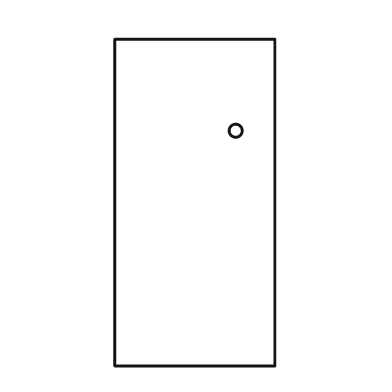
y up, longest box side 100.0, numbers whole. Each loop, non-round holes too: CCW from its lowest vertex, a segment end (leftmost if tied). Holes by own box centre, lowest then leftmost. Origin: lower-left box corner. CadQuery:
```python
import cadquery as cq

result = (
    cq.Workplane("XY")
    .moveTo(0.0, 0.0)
    .lineTo(49.0, 0.0)
    .lineTo(49.0, 100.0)
    .lineTo(0.0, 100.0)
    .close()
    .moveTo(37.0, 72.0)
    .circle(2.0)
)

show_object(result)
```